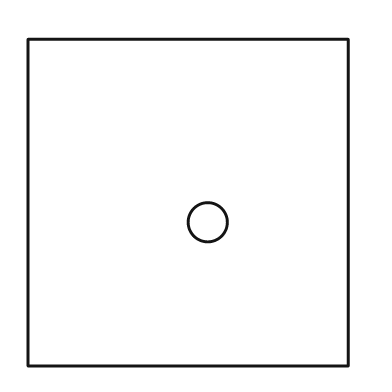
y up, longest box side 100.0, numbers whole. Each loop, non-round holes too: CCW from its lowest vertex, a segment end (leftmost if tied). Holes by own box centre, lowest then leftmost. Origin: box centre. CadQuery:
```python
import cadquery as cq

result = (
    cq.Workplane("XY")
    .moveTo(-49.0, -50.0)
    .lineTo(49.0, -50.0)
    .lineTo(49.0, 50.0)
    .lineTo(-49.0, 50.0)
    .close()
    .moveTo(6.0, -6.0)
    .circle(6.0)
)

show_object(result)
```